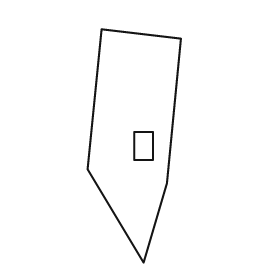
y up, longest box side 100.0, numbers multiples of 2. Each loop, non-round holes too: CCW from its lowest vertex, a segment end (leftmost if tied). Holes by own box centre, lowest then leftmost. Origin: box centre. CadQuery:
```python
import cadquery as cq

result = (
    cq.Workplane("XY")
    .moveTo(4.0, -50.0)
    .lineTo(14.0, -16.0)
    .lineTo(20.0, 46.0)
    .lineTo(-14.0, 50.0)
    .lineTo(-20.0, -10.0)
    .close()
    .moveTo(0.0, -6.0)
    .lineTo(8.0, -6.0)
    .lineTo(8.0, 6.0)
    .lineTo(0.0, 6.0)
    .close()
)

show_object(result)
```